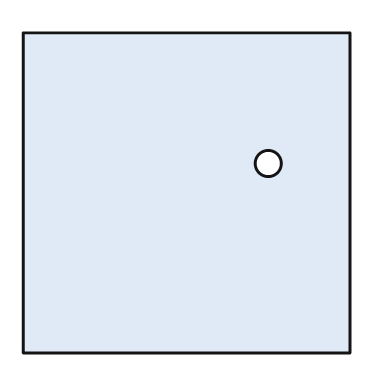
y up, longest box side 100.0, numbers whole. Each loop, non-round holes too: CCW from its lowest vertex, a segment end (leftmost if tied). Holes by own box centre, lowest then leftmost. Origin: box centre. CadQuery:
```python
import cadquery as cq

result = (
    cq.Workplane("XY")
    .moveTo(-50.0, -49.0)
    .lineTo(50.0, -49.0)
    .lineTo(50.0, 49.0)
    .lineTo(-50.0, 49.0)
    .close()
    .moveTo(25.0, 9.0)
    .circle(4.0)
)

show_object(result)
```